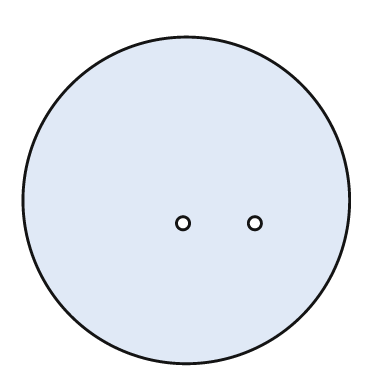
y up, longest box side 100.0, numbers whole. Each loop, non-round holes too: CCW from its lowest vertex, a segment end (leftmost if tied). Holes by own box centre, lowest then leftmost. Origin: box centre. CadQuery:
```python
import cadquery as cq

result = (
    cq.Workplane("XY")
    .moveTo(0.0, 0.0)
    .circle(50.0)
    .moveTo(-1.0, -7.0)
    .circle(2.0)
    .moveTo(21.0, -7.0)
    .circle(2.0)
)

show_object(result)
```